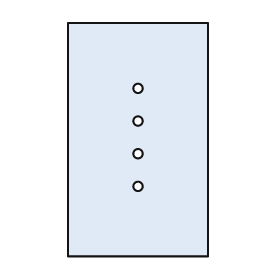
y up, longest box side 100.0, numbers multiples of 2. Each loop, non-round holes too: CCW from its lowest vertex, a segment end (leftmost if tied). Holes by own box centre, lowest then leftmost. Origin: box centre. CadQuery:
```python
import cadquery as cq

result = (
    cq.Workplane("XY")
    .moveTo(-30.0, -50.0)
    .lineTo(30.0, -50.0)
    .lineTo(30.0, 50.0)
    .lineTo(-30.0, 50.0)
    .close()
    .moveTo(0.0, -20.0)
    .circle(2.0)
    .moveTo(0.0, -6.0)
    .circle(2.0)
    .moveTo(0.0, 8.0)
    .circle(2.0)
    .moveTo(0.0, 22.0)
    .circle(2.0)
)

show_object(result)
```